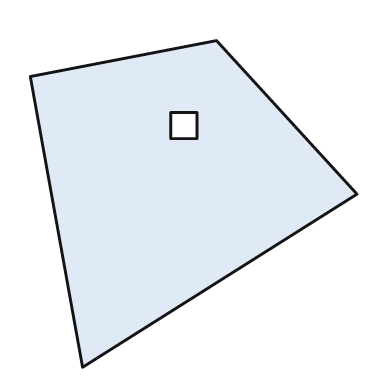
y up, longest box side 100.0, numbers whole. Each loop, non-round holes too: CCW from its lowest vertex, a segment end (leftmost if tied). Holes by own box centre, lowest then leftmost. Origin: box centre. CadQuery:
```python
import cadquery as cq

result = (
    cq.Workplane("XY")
    .moveTo(-34.0, -50.0)
    .lineTo(50.0, 3.0)
    .lineTo(7.0, 50.0)
    .lineTo(-50.0, 39.0)
    .close()
    .moveTo(-7.0, 20.0)
    .lineTo(1.0, 20.0)
    .lineTo(1.0, 28.0)
    .lineTo(-7.0, 28.0)
    .close()
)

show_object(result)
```